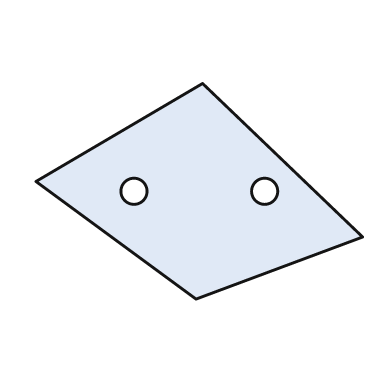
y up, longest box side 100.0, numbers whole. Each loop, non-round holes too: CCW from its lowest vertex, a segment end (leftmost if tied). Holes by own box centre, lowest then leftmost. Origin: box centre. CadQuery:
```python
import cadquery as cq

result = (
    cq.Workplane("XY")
    .moveTo(-1.0, -33.0)
    .lineTo(50.0, -14.0)
    .lineTo(1.0, 33.0)
    .lineTo(-50.0, 3.0)
    .close()
    .moveTo(-20.0, 0.0)
    .circle(4.0)
    .moveTo(20.0, 0.0)
    .circle(4.0)
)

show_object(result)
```